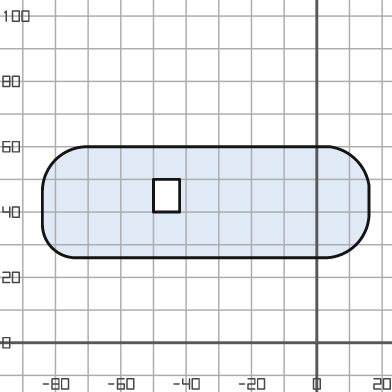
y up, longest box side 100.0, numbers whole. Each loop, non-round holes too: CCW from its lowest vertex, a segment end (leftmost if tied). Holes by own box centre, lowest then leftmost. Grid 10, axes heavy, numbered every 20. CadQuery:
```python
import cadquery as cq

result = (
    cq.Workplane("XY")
    .moveTo(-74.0, 26.0)
    .lineTo(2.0, 26.0)
    .threePointArc((12.0, 30.0), (16.0, 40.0))
    .lineTo(16.0, 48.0)
    .threePointArc((12.0, 56.0), (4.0, 60.0))
    .lineTo(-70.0, 60.0)
    .threePointArc((-80.0, 56.0), (-84.0, 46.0))
    .lineTo(-84.0, 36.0)
    .threePointArc((-81.0, 29.0), (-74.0, 26.0))
    .close()
    .moveTo(-50.0, 40.0)
    .lineTo(-42.0, 40.0)
    .lineTo(-42.0, 50.0)
    .lineTo(-50.0, 50.0)
    .close()
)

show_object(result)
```